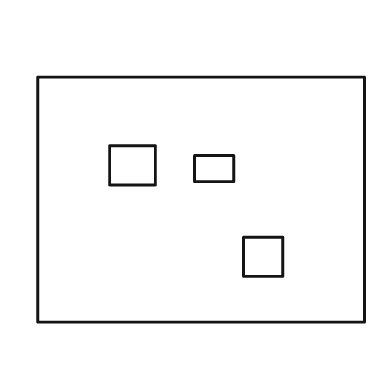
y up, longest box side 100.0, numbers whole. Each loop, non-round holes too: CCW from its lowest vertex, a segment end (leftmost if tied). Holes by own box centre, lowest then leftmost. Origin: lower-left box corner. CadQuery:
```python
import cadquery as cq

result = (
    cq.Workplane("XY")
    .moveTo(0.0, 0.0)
    .lineTo(100.0, 0.0)
    .lineTo(100.0, 75.0)
    .lineTo(0.0, 75.0)
    .close()
    .moveTo(63.0, 14.0)
    .lineTo(75.0, 14.0)
    .lineTo(75.0, 26.0)
    .lineTo(63.0, 26.0)
    .close()
    .moveTo(48.0, 43.0)
    .lineTo(60.0, 43.0)
    .lineTo(60.0, 51.0)
    .lineTo(48.0, 51.0)
    .close()
    .moveTo(22.0, 42.0)
    .lineTo(36.0, 42.0)
    .lineTo(36.0, 54.0)
    .lineTo(22.0, 54.0)
    .close()
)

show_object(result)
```